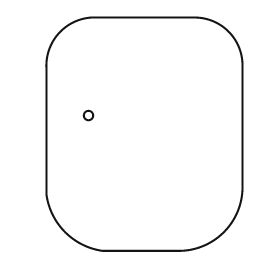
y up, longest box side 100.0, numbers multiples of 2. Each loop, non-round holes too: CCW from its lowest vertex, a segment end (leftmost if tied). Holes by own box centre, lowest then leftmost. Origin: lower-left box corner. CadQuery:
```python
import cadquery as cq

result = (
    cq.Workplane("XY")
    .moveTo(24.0, 0.0)
    .lineTo(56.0, 0.0)
    .threePointArc((76.0, 8.0), (84.0, 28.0))
    .lineTo(84.0, 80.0)
    .threePointArc((78.0, 94.0), (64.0, 100.0))
    .lineTo(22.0, 100.0)
    .threePointArc((6.0, 94.0), (0.0, 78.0))
    .lineTo(0.0, 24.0)
    .threePointArc((8.0, 8.0), (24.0, 0.0))
    .close()
    .moveTo(18.0, 58.0)
    .circle(2.0)
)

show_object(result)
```